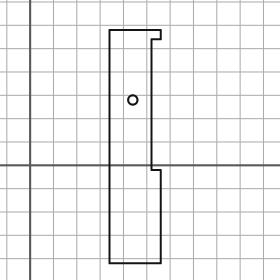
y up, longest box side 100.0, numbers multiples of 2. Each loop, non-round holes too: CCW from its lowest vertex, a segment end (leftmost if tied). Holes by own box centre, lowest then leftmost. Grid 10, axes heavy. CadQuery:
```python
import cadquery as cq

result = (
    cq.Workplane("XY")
    .moveTo(34.0, -42.0)
    .lineTo(56.0, -42.0)
    .lineTo(56.0, -2.0)
    .lineTo(52.0, -2.0)
    .lineTo(52.0, 54.0)
    .lineTo(56.0, 54.0)
    .lineTo(56.0, 58.0)
    .lineTo(34.0, 58.0)
    .close()
    .moveTo(44.0, 28.0)
    .circle(2.0)
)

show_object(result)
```